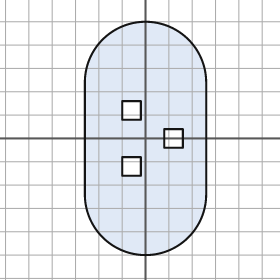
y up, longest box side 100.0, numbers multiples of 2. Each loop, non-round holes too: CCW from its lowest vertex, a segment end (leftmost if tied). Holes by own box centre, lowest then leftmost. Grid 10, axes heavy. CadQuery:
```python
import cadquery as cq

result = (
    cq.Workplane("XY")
    .moveTo(-26.0, -24.0)
    .threePointArc((0.0, -50.0), (26.0, -24.0))
    .lineTo(26.0, 24.0)
    .threePointArc((0.0, 50.0), (-26.0, 24.0))
    .close()
    .moveTo(-10.0, -16.0)
    .lineTo(-2.0, -16.0)
    .lineTo(-2.0, -8.0)
    .lineTo(-10.0, -8.0)
    .close()
    .moveTo(8.0, -4.0)
    .lineTo(16.0, -4.0)
    .lineTo(16.0, 4.0)
    .lineTo(8.0, 4.0)
    .close()
    .moveTo(-10.0, 8.0)
    .lineTo(-2.0, 8.0)
    .lineTo(-2.0, 16.0)
    .lineTo(-10.0, 16.0)
    .close()
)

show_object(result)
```